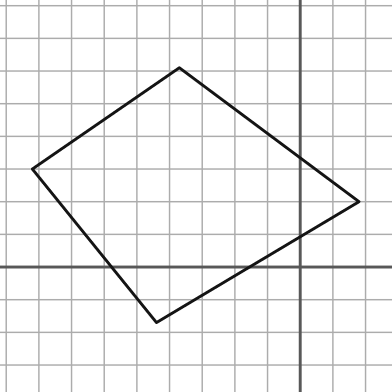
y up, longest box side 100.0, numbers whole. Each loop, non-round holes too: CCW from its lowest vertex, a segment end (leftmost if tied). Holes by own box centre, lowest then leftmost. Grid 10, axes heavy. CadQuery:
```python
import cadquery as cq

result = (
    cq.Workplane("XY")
    .moveTo(-44.0, -17.0)
    .lineTo(18.0, 20.0)
    .lineTo(-37.0, 61.0)
    .lineTo(-82.0, 30.0)
    .close()
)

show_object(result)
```